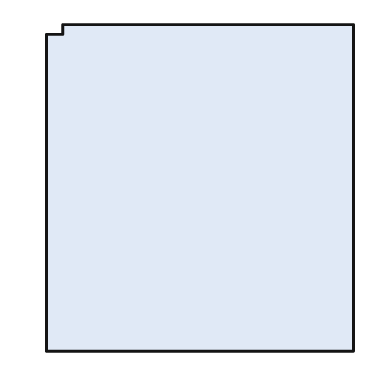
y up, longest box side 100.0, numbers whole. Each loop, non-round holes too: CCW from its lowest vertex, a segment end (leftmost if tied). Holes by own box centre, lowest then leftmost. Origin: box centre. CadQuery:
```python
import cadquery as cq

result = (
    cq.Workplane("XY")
    .moveTo(-47.0, -50.0)
    .lineTo(47.0, -50.0)
    .lineTo(47.0, 50.0)
    .lineTo(-42.0, 50.0)
    .lineTo(-42.0, 47.0)
    .lineTo(-47.0, 47.0)
    .close()
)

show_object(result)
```